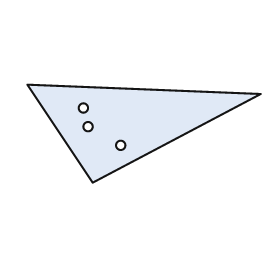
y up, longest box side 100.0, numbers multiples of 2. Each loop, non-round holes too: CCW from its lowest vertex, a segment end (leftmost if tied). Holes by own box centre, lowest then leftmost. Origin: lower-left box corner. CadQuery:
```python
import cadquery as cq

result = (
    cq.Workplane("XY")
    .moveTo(28.0, 0.0)
    .lineTo(100.0, 38.0)
    .lineTo(0.0, 42.0)
    .close()
    .moveTo(40.0, 16.0)
    .circle(2.0)
    .moveTo(26.0, 24.0)
    .circle(2.0)
    .moveTo(24.0, 32.0)
    .circle(2.0)
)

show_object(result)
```